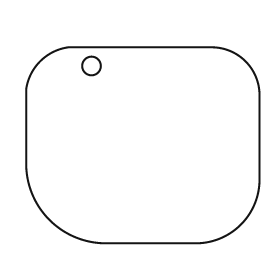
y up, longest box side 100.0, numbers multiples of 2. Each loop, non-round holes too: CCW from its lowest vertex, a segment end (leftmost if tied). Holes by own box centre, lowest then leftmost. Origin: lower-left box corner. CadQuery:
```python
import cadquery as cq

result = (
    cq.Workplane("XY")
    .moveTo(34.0, 0.0)
    .lineTo(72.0, 0.0)
    .threePointArc((92.0, 8.0), (100.0, 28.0))
    .lineTo(100.0, 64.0)
    .threePointArc((94.0, 78.0), (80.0, 84.0))
    .lineTo(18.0, 84.0)
    .threePointArc((6.0, 78.0), (0.0, 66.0))
    .lineTo(0.0, 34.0)
    .threePointArc((10.0, 10.0), (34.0, 0.0))
    .close()
    .moveTo(28.0, 76.0)
    .circle(4.0)
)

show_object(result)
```